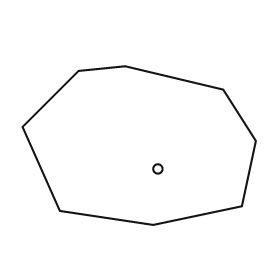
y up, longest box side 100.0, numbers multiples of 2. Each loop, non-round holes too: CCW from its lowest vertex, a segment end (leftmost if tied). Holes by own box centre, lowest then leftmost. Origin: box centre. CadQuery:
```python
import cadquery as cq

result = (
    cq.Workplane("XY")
    .moveTo(6.0, -34.0)
    .lineTo(44.0, -26.0)
    .lineTo(50.0, 2.0)
    .lineTo(36.0, 24.0)
    .lineTo(-6.0, 34.0)
    .lineTo(-26.0, 32.0)
    .lineTo(-50.0, 8.0)
    .lineTo(-34.0, -28.0)
    .close()
    .moveTo(8.0, -10.0)
    .circle(2.0)
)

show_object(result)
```